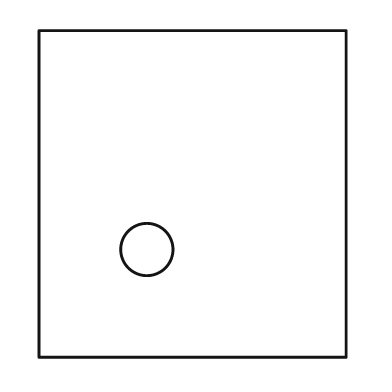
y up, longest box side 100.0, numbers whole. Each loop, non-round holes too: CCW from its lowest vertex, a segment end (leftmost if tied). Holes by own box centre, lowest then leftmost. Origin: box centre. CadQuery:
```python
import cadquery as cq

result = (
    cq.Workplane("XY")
    .moveTo(-47.0, -50.0)
    .lineTo(47.0, -50.0)
    .lineTo(47.0, 50.0)
    .lineTo(-47.0, 50.0)
    .close()
    .moveTo(-14.0, -17.0)
    .circle(8.0)
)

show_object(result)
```